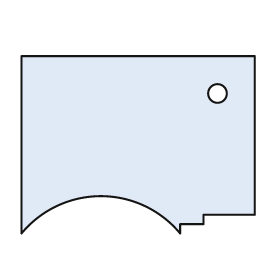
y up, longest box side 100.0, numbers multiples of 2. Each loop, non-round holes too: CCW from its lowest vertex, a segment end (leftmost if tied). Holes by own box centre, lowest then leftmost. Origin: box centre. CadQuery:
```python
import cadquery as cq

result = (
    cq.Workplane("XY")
    .moveTo(-50.0, -38.0)
    .threePointArc((-16.0, -22.0), (18.0, -38.0))
    .lineTo(18.0, -34.0)
    .lineTo(28.0, -34.0)
    .lineTo(28.0, -30.0)
    .lineTo(50.0, -30.0)
    .lineTo(50.0, 38.0)
    .lineTo(-50.0, 38.0)
    .close()
    .moveTo(34.0, 22.0)
    .circle(4.0)
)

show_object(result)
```